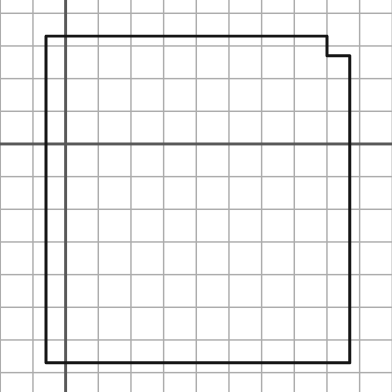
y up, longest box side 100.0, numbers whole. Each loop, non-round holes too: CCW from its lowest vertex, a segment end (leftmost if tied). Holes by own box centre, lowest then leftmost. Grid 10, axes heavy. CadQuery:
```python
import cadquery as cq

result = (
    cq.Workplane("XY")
    .moveTo(-6.0, -67.0)
    .lineTo(87.0, -67.0)
    .lineTo(87.0, 27.0)
    .lineTo(80.0, 27.0)
    .lineTo(80.0, 33.0)
    .lineTo(-6.0, 33.0)
    .close()
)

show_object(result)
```